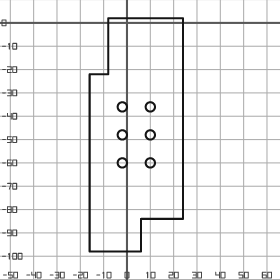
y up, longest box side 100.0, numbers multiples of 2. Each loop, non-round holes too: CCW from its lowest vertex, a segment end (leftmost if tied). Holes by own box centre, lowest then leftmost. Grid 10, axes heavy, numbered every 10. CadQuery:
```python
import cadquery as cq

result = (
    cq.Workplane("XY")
    .moveTo(-16.0, -98.0)
    .lineTo(6.0, -98.0)
    .lineTo(6.0, -84.0)
    .lineTo(24.0, -84.0)
    .lineTo(24.0, 2.0)
    .lineTo(-8.0, 2.0)
    .lineTo(-8.0, -22.0)
    .lineTo(-16.0, -22.0)
    .close()
    .moveTo(-2.0, -60.0)
    .circle(2.0)
    .moveTo(10.0, -60.0)
    .circle(2.0)
    .moveTo(-2.0, -48.0)
    .circle(2.0)
    .moveTo(10.0, -48.0)
    .circle(2.0)
    .moveTo(-2.0, -36.0)
    .circle(2.0)
    .moveTo(10.0, -36.0)
    .circle(2.0)
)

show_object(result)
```